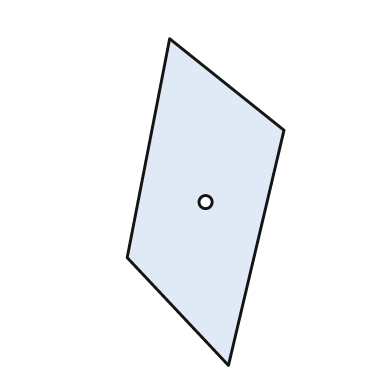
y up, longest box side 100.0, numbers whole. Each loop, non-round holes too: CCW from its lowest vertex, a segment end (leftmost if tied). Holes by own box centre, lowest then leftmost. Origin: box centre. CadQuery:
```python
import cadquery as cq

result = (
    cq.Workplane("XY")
    .moveTo(7.0, -50.0)
    .lineTo(24.0, 22.0)
    .lineTo(-11.0, 50.0)
    .lineTo(-24.0, -17.0)
    .close()
    .moveTo(0.0, 0.0)
    .circle(2.0)
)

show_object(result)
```